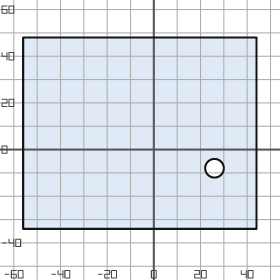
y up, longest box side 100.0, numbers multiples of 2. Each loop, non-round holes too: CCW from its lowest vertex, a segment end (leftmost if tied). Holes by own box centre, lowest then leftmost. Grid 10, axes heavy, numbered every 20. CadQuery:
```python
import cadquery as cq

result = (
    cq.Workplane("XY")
    .moveTo(-56.0, -34.0)
    .lineTo(44.0, -34.0)
    .lineTo(44.0, 48.0)
    .lineTo(-56.0, 48.0)
    .close()
    .moveTo(26.0, -8.0)
    .circle(4.0)
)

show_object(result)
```